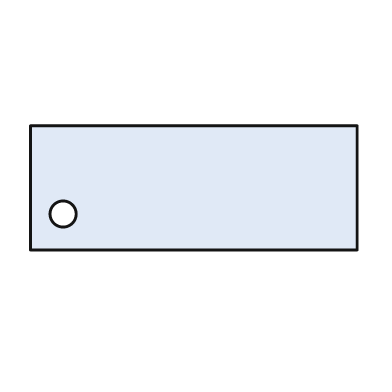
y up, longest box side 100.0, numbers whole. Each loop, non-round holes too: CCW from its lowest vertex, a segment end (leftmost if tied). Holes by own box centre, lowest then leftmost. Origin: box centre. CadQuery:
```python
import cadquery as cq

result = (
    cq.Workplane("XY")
    .moveTo(-50.0, -19.0)
    .lineTo(50.0, -19.0)
    .lineTo(50.0, 19.0)
    .lineTo(-50.0, 19.0)
    .close()
    .moveTo(-40.0, -8.0)
    .circle(4.0)
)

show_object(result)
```